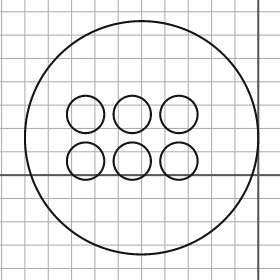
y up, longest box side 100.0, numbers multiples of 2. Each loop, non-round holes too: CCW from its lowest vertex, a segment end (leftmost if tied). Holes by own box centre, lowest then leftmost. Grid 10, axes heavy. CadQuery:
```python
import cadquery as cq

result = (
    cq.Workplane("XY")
    .moveTo(-50.0, 16.0)
    .circle(50.0)
    .moveTo(-74.0, 6.0)
    .circle(8.0)
    .moveTo(-54.0, 6.0)
    .circle(8.0)
    .moveTo(-34.0, 6.0)
    .circle(8.0)
    .moveTo(-74.0, 26.0)
    .circle(8.0)
    .moveTo(-54.0, 26.0)
    .circle(8.0)
    .moveTo(-34.0, 26.0)
    .circle(8.0)
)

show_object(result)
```